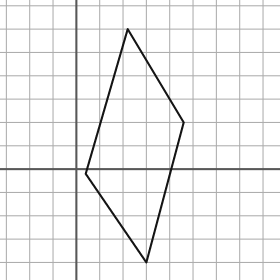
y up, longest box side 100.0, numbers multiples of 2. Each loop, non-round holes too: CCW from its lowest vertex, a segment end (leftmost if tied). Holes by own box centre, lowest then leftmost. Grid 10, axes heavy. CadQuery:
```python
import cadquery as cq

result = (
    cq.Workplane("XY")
    .moveTo(30.0, -40.0)
    .lineTo(46.0, 20.0)
    .lineTo(22.0, 60.0)
    .lineTo(4.0, -2.0)
    .close()
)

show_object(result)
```